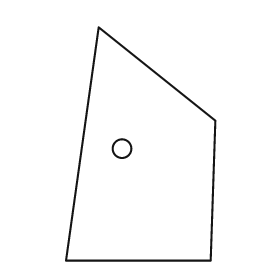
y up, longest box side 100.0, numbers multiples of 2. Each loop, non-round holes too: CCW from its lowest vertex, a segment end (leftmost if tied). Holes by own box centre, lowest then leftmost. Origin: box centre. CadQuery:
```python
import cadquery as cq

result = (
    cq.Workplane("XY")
    .moveTo(-32.0, -50.0)
    .lineTo(30.0, -50.0)
    .lineTo(32.0, 10.0)
    .lineTo(-18.0, 50.0)
    .close()
    .moveTo(-8.0, -2.0)
    .circle(4.0)
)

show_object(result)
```